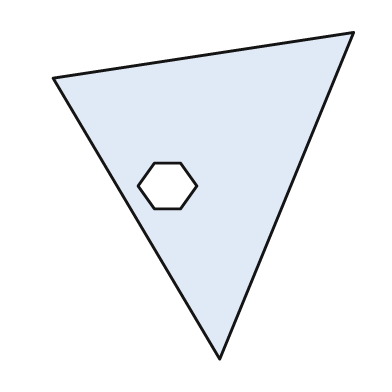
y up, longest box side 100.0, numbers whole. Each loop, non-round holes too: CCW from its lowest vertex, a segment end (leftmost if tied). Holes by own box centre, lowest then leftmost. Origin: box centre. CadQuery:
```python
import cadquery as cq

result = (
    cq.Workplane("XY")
    .moveTo(5.0, -50.0)
    .lineTo(46.0, 50.0)
    .lineTo(-46.0, 36.0)
    .close()
    .moveTo(-15.0, -4.0)
    .lineTo(-7.0, -4.0)
    .lineTo(-2.0, 3.0)
    .lineTo(-7.0, 10.0)
    .lineTo(-15.0, 10.0)
    .lineTo(-20.0, 3.0)
    .close()
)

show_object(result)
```